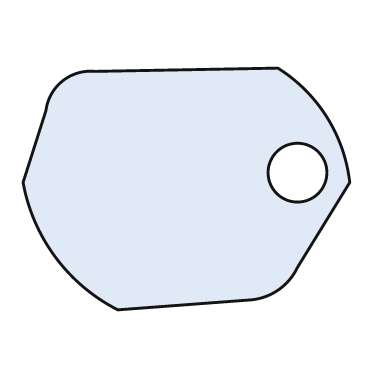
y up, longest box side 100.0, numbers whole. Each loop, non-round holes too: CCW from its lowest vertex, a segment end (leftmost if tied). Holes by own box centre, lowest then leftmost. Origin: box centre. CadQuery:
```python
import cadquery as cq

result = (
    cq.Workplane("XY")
    .moveTo(-21.0, -37.0)
    .lineTo(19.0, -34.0)
    .threePointArc((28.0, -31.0), (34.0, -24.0))
    .lineTo(50.0, 2.0)
    .threePointArc((43.0, 22.0), (28.0, 37.0))
    .lineTo(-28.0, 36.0)
    .threePointArc((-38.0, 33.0), (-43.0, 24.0))
    .lineTo(-50.0, 2.0)
    .threePointArc((-40.0, -21.0), (-21.0, -37.0))
    .close()
    .moveTo(34.0, 5.0)
    .circle(9.0)
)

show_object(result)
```